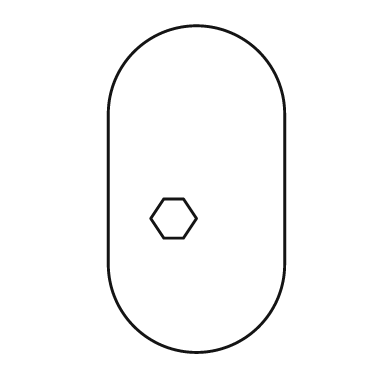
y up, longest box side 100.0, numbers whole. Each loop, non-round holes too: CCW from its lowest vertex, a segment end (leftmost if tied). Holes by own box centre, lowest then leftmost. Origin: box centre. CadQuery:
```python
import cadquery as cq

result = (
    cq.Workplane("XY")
    .moveTo(-27.0, -23.0)
    .threePointArc((0.0, -50.0), (27.0, -23.0))
    .lineTo(27.0, 23.0)
    .threePointArc((0.0, 50.0), (-27.0, 23.0))
    .close()
    .moveTo(-10.0, -15.0)
    .lineTo(-4.0, -15.0)
    .lineTo(0.0, -9.0)
    .lineTo(-4.0, -3.0)
    .lineTo(-10.0, -3.0)
    .lineTo(-14.0, -9.0)
    .close()
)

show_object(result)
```